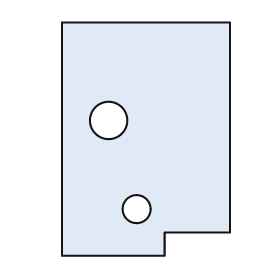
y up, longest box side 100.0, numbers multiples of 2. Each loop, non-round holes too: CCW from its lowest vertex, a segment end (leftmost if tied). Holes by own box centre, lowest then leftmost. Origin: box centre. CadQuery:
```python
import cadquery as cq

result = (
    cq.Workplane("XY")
    .moveTo(-36.0, -50.0)
    .lineTo(8.0, -50.0)
    .lineTo(8.0, -40.0)
    .lineTo(36.0, -40.0)
    .lineTo(36.0, 50.0)
    .lineTo(-36.0, 50.0)
    .close()
    .moveTo(-4.0, -30.0)
    .circle(6.0)
    .moveTo(-16.0, 8.0)
    .circle(8.0)
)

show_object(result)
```